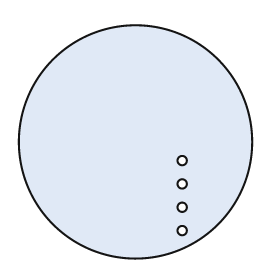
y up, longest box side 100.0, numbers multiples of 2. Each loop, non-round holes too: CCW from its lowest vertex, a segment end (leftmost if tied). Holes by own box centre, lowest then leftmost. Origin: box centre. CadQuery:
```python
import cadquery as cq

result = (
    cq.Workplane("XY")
    .moveTo(0.0, 0.0)
    .circle(50.0)
    .moveTo(20.0, -38.0)
    .circle(2.0)
    .moveTo(20.0, -28.0)
    .circle(2.0)
    .moveTo(20.0, -18.0)
    .circle(2.0)
    .moveTo(20.0, -8.0)
    .circle(2.0)
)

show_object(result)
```